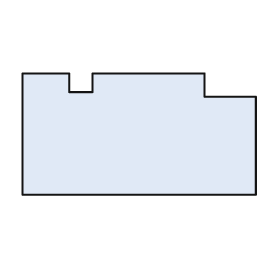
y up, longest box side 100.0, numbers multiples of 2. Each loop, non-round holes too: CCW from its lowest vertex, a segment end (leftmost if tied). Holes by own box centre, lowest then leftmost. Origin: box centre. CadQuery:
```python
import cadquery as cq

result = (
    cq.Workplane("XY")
    .moveTo(-50.0, -26.0)
    .lineTo(50.0, -26.0)
    .lineTo(50.0, 16.0)
    .lineTo(28.0, 16.0)
    .lineTo(28.0, 26.0)
    .lineTo(-20.0, 26.0)
    .lineTo(-20.0, 18.0)
    .lineTo(-30.0, 18.0)
    .lineTo(-30.0, 26.0)
    .lineTo(-50.0, 26.0)
    .close()
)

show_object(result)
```